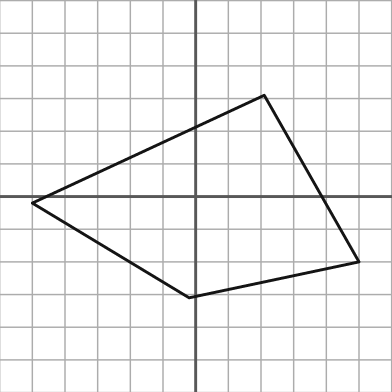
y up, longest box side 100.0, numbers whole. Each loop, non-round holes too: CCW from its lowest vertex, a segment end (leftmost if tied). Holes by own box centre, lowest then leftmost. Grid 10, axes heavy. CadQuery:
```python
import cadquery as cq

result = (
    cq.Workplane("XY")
    .moveTo(-2.0, -31.0)
    .lineTo(50.0, -20.0)
    .lineTo(21.0, 31.0)
    .lineTo(-50.0, -2.0)
    .close()
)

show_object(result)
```